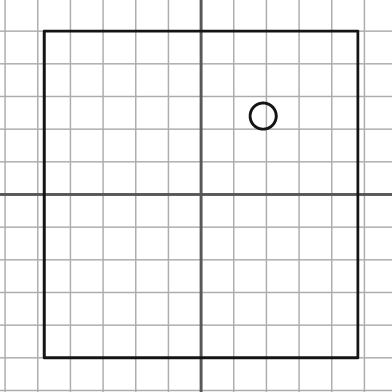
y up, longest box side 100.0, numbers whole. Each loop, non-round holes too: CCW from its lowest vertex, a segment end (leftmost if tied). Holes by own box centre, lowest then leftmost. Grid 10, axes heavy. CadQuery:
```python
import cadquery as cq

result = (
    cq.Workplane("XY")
    .moveTo(-48.0, -50.0)
    .lineTo(48.0, -50.0)
    .lineTo(48.0, 50.0)
    .lineTo(-48.0, 50.0)
    .close()
    .moveTo(19.0, 24.0)
    .circle(4.0)
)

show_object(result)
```